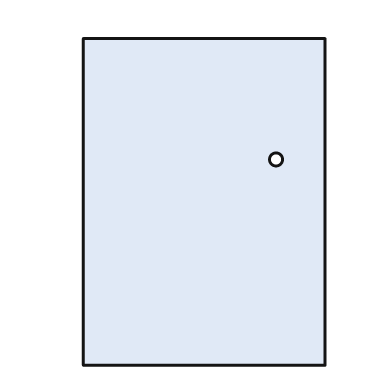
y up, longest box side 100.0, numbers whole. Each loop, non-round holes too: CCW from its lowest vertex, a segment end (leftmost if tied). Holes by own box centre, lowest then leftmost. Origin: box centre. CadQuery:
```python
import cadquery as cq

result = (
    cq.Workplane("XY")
    .moveTo(-37.0, -50.0)
    .lineTo(37.0, -50.0)
    .lineTo(37.0, 50.0)
    .lineTo(-37.0, 50.0)
    .close()
    .moveTo(22.0, 13.0)
    .circle(2.0)
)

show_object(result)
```